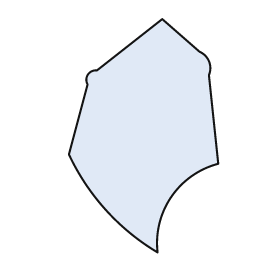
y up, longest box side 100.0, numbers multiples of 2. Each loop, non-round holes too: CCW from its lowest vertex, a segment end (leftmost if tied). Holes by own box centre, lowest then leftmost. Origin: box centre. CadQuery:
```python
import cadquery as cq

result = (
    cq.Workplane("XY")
    .moveTo(6.0, -50.0)
    .threePointArc((12.0, -26.0), (32.0, -12.0))
    .lineTo(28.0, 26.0)
    .threePointArc((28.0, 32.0), (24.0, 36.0))
    .lineTo(8.0, 50.0)
    .lineTo(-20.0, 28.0)
    .threePointArc((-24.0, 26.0), (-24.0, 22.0))
    .lineTo(-32.0, -8.0)
    .threePointArc((-16.0, -32.0), (6.0, -50.0))
    .close()
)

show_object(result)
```